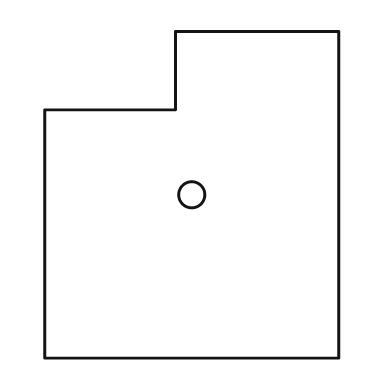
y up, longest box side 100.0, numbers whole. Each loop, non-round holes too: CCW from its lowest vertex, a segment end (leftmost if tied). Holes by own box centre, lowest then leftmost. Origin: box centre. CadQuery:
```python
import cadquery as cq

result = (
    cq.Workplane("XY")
    .moveTo(-45.0, -50.0)
    .lineTo(45.0, -50.0)
    .lineTo(45.0, 50.0)
    .lineTo(-5.0, 50.0)
    .lineTo(-5.0, 26.0)
    .lineTo(-45.0, 26.0)
    .close()
    .moveTo(0.0, 0.0)
    .circle(4.0)
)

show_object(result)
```